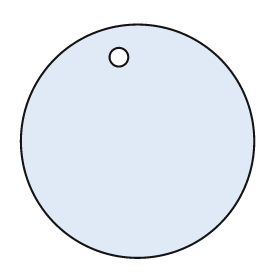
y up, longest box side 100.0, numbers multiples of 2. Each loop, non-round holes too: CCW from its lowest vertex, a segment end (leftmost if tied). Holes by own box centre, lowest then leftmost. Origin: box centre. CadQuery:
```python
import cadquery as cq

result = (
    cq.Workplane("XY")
    .moveTo(0.0, 0.0)
    .circle(50.0)
    .moveTo(-8.0, 36.0)
    .circle(4.0)
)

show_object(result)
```